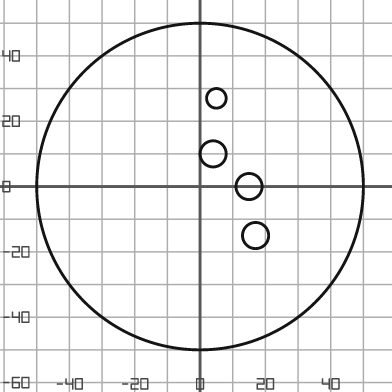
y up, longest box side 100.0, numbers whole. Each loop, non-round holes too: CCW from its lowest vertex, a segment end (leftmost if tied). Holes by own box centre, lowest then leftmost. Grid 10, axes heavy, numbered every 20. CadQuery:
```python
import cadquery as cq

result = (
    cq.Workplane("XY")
    .moveTo(0.0, 0.0)
    .circle(50.0)
    .moveTo(17.0, -15.0)
    .circle(4.0)
    .moveTo(15.0, 0.0)
    .circle(4.0)
    .moveTo(4.0, 10.0)
    .circle(4.0)
    .moveTo(5.0, 27.0)
    .circle(3.0)
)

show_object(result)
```